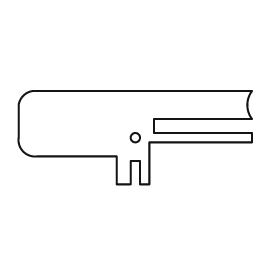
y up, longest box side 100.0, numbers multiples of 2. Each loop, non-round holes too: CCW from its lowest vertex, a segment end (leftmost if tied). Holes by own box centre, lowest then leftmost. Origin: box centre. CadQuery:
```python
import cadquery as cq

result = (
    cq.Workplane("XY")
    .moveTo(-8.0, -20.0)
    .lineTo(-2.0, -20.0)
    .lineTo(-2.0, -10.0)
    .lineTo(2.0, -10.0)
    .lineTo(2.0, -20.0)
    .lineTo(6.0, -20.0)
    .lineTo(6.0, -2.0)
    .lineTo(50.0, -2.0)
    .lineTo(50.0, 2.0)
    .lineTo(8.0, 2.0)
    .lineTo(8.0, 8.0)
    .lineTo(50.0, 8.0)
    .threePointArc((48.0, 14.0), (50.0, 20.0))
    .lineTo(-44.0, 20.0)
    .threePointArc((-48.0, 18.0), (-50.0, 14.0))
    .lineTo(-50.0, 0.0)
    .threePointArc((-48.0, -6.0), (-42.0, -8.0))
    .lineTo(-8.0, -8.0)
    .close()
    .moveTo(0.0, 0.0)
    .circle(2.0)
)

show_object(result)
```